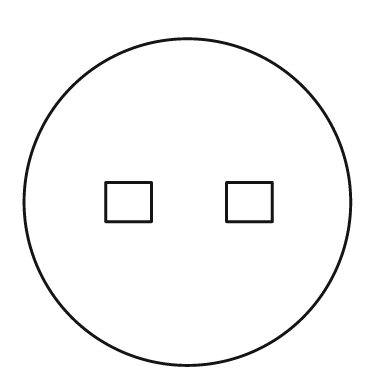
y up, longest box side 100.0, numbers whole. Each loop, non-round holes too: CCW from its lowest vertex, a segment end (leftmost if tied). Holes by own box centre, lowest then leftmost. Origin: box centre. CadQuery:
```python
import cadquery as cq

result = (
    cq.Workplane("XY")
    .moveTo(0.0, 0.0)
    .circle(50.0)
    .moveTo(-25.0, -6.0)
    .lineTo(-11.0, -6.0)
    .lineTo(-11.0, 6.0)
    .lineTo(-25.0, 6.0)
    .close()
    .moveTo(12.0, -6.0)
    .lineTo(26.0, -6.0)
    .lineTo(26.0, 6.0)
    .lineTo(12.0, 6.0)
    .close()
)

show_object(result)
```